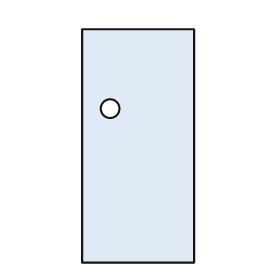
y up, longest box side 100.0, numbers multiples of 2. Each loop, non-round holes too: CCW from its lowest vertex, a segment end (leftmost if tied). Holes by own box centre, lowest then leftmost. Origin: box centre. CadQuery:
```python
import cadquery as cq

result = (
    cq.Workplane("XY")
    .moveTo(-24.0, -50.0)
    .lineTo(24.0, -50.0)
    .lineTo(24.0, 50.0)
    .lineTo(-24.0, 50.0)
    .close()
    .moveTo(-12.0, 16.0)
    .circle(4.0)
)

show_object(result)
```